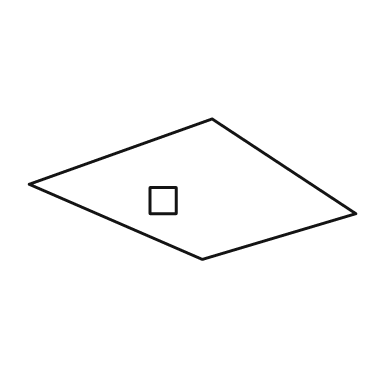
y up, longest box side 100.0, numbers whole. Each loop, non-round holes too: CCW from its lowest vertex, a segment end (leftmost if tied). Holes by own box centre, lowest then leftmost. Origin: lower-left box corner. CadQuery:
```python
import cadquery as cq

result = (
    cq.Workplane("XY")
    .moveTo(53.0, 0.0)
    .lineTo(100.0, 14.0)
    .lineTo(56.0, 43.0)
    .lineTo(0.0, 23.0)
    .close()
    .moveTo(37.0, 14.0)
    .lineTo(45.0, 14.0)
    .lineTo(45.0, 22.0)
    .lineTo(37.0, 22.0)
    .close()
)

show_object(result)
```